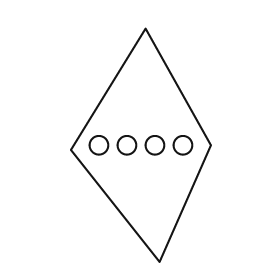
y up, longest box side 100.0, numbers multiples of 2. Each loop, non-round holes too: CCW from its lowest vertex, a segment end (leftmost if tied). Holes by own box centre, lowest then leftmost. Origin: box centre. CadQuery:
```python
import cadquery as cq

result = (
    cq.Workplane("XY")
    .moveTo(8.0, -50.0)
    .lineTo(30.0, 0.0)
    .lineTo(2.0, 50.0)
    .lineTo(-30.0, -2.0)
    .close()
    .moveTo(-18.0, 0.0)
    .circle(4.0)
    .moveTo(-6.0, 0.0)
    .circle(4.0)
    .moveTo(6.0, 0.0)
    .circle(4.0)
    .moveTo(18.0, 0.0)
    .circle(4.0)
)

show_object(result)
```